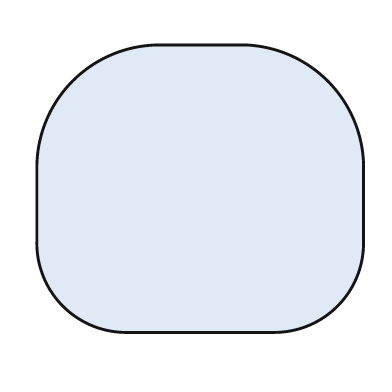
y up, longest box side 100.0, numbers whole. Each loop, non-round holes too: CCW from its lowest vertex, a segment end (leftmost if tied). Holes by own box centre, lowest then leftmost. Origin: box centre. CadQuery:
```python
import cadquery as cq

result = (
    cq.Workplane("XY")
    .moveTo(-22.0, -44.0)
    .lineTo(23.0, -44.0)
    .threePointArc((42.0, -36.0), (50.0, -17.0))
    .lineTo(50.0, 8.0)
    .threePointArc((39.0, 33.0), (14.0, 44.0))
    .lineTo(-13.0, 44.0)
    .threePointArc((-39.0, 33.0), (-50.0, 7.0))
    .lineTo(-50.0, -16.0)
    .threePointArc((-42.0, -36.0), (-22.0, -44.0))
    .close()
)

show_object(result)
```